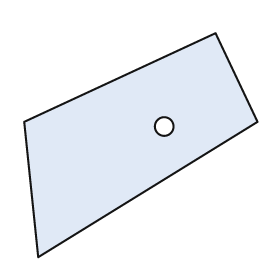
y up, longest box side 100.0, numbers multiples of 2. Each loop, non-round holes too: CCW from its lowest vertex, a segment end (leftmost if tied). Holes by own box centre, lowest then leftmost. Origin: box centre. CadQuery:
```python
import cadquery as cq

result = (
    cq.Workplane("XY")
    .moveTo(-44.0, -48.0)
    .lineTo(50.0, 10.0)
    .lineTo(32.0, 48.0)
    .lineTo(-50.0, 10.0)
    .close()
    .moveTo(10.0, 8.0)
    .circle(4.0)
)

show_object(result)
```